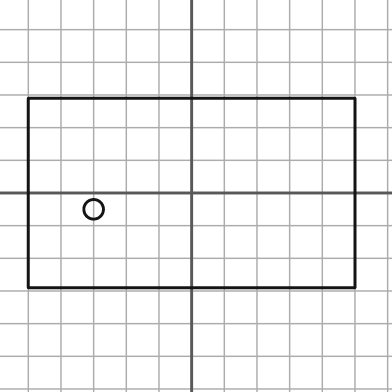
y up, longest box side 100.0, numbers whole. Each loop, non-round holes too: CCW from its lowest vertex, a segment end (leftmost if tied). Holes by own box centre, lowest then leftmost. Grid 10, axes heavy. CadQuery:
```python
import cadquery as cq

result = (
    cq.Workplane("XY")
    .moveTo(-50.0, -29.0)
    .lineTo(50.0, -29.0)
    .lineTo(50.0, 29.0)
    .lineTo(-50.0, 29.0)
    .close()
    .moveTo(-30.0, -5.0)
    .circle(3.0)
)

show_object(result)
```